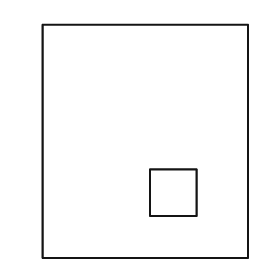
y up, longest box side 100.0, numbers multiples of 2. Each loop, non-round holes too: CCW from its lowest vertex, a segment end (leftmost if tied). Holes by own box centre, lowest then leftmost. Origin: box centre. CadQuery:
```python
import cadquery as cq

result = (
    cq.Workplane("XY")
    .moveTo(-44.0, -50.0)
    .lineTo(44.0, -50.0)
    .lineTo(44.0, 50.0)
    .lineTo(-44.0, 50.0)
    .close()
    .moveTo(2.0, -32.0)
    .lineTo(22.0, -32.0)
    .lineTo(22.0, -12.0)
    .lineTo(2.0, -12.0)
    .close()
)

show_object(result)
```